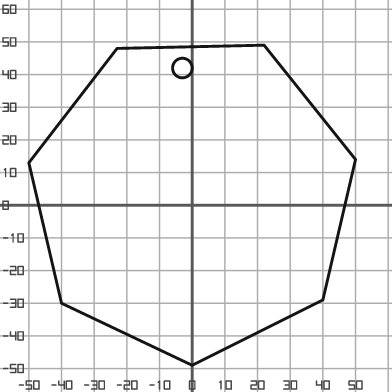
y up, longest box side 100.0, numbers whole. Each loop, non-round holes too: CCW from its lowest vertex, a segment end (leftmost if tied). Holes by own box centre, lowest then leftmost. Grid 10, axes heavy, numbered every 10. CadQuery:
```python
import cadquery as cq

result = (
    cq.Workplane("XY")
    .moveTo(0.0, -49.0)
    .lineTo(40.0, -29.0)
    .lineTo(50.0, 14.0)
    .lineTo(22.0, 49.0)
    .lineTo(-23.0, 48.0)
    .lineTo(-50.0, 13.0)
    .lineTo(-40.0, -30.0)
    .close()
    .moveTo(-3.0, 42.0)
    .circle(3.0)
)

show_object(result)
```